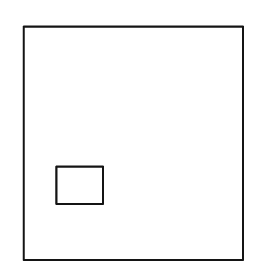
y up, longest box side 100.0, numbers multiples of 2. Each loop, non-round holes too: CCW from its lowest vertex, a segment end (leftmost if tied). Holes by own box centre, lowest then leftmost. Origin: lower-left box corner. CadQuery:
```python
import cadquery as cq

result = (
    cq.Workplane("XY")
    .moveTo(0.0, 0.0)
    .lineTo(94.0, 0.0)
    .lineTo(94.0, 100.0)
    .lineTo(0.0, 100.0)
    .close()
    .moveTo(14.0, 24.0)
    .lineTo(34.0, 24.0)
    .lineTo(34.0, 40.0)
    .lineTo(14.0, 40.0)
    .close()
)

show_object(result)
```